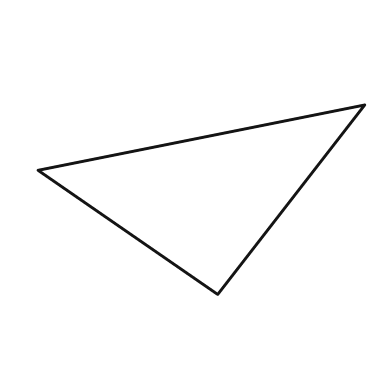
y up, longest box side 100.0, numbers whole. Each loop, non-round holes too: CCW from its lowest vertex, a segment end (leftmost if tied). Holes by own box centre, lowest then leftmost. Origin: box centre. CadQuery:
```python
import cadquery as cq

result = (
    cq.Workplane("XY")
    .moveTo(5.0, -29.0)
    .lineTo(50.0, 29.0)
    .lineTo(-50.0, 9.0)
    .close()
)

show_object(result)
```